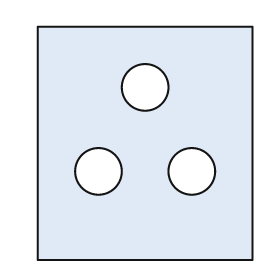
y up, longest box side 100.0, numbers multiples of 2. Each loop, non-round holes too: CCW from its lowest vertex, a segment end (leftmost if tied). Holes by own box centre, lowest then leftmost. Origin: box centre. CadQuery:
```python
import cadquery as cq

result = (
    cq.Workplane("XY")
    .moveTo(-46.0, -50.0)
    .lineTo(46.0, -50.0)
    .lineTo(46.0, 50.0)
    .lineTo(-46.0, 50.0)
    .close()
    .moveTo(-20.0, -12.0)
    .circle(10.0)
    .moveTo(20.0, -12.0)
    .circle(10.0)
    .moveTo(0.0, 24.0)
    .circle(10.0)
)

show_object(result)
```